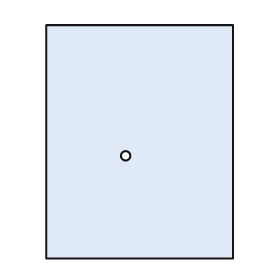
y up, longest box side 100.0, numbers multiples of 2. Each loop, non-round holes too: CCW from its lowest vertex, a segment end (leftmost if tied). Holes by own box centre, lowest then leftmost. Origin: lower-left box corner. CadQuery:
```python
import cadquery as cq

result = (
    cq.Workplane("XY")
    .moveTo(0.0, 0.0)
    .lineTo(80.0, 0.0)
    .lineTo(80.0, 100.0)
    .lineTo(0.0, 100.0)
    .close()
    .moveTo(34.0, 44.0)
    .circle(2.0)
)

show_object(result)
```